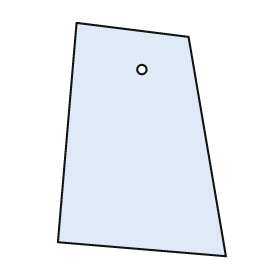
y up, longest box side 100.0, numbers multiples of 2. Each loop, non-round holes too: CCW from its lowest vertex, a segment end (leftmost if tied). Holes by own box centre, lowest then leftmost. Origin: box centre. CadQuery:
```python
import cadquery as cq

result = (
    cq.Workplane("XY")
    .moveTo(36.0, -50.0)
    .lineTo(20.0, 44.0)
    .lineTo(-28.0, 50.0)
    .lineTo(-36.0, -44.0)
    .close()
    .moveTo(0.0, 30.0)
    .circle(2.0)
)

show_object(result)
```